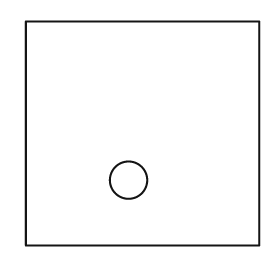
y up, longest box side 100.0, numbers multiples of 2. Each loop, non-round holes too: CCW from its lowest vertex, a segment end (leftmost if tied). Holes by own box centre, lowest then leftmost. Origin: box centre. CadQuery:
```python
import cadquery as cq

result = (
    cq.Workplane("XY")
    .moveTo(-50.0, -48.0)
    .lineTo(50.0, -48.0)
    .lineTo(50.0, 48.0)
    .lineTo(-50.0, 48.0)
    .close()
    .moveTo(-6.0, -20.0)
    .circle(8.0)
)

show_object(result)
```